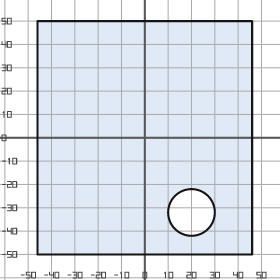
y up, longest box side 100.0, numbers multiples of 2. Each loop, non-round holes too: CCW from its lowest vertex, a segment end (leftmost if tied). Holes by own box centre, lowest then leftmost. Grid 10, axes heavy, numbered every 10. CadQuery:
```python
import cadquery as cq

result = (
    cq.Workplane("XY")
    .moveTo(-46.0, -50.0)
    .lineTo(46.0, -50.0)
    .lineTo(46.0, 50.0)
    .lineTo(-46.0, 50.0)
    .close()
    .moveTo(20.0, -32.0)
    .circle(10.0)
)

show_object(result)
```